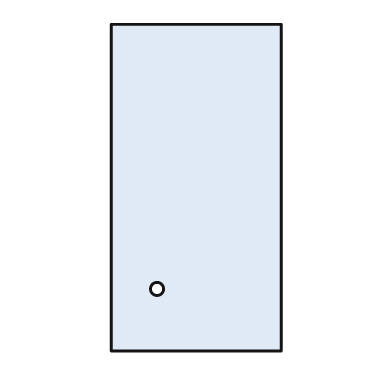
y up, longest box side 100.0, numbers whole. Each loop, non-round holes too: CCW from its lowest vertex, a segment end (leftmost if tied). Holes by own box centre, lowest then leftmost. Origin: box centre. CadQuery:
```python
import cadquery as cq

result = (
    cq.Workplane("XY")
    .moveTo(-26.0, -50.0)
    .lineTo(26.0, -50.0)
    .lineTo(26.0, 50.0)
    .lineTo(-26.0, 50.0)
    .close()
    .moveTo(-12.0, -31.0)
    .circle(2.0)
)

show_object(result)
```